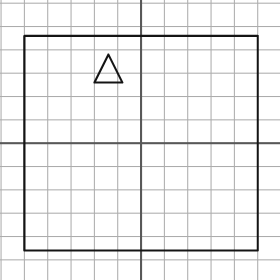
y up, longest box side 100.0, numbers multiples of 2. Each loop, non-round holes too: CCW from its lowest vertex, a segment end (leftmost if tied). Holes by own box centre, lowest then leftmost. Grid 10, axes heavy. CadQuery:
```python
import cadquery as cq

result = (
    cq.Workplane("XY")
    .moveTo(-50.0, -46.0)
    .lineTo(50.0, -46.0)
    .lineTo(50.0, 46.0)
    .lineTo(-50.0, 46.0)
    .close()
    .moveTo(-20.0, 26.0)
    .lineTo(-8.0, 26.0)
    .lineTo(-14.0, 38.0)
    .close()
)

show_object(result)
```